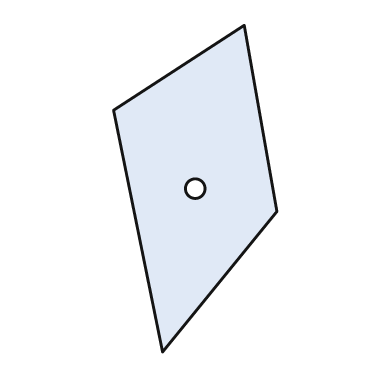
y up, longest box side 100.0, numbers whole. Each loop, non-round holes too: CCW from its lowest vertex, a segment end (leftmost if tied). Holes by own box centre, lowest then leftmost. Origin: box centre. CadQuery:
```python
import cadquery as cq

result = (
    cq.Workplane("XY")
    .moveTo(-10.0, -50.0)
    .lineTo(25.0, -7.0)
    .lineTo(15.0, 50.0)
    .lineTo(-25.0, 24.0)
    .close()
    .moveTo(0.0, 0.0)
    .circle(3.0)
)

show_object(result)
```